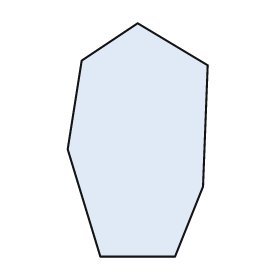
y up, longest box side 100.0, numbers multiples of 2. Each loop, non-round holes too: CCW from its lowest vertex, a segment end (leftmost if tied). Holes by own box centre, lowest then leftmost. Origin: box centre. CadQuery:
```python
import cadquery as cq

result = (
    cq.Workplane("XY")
    .moveTo(-16.0, -50.0)
    .lineTo(16.0, -50.0)
    .lineTo(28.0, -20.0)
    .lineTo(30.0, 32.0)
    .lineTo(0.0, 50.0)
    .lineTo(-24.0, 34.0)
    .lineTo(-30.0, -4.0)
    .close()
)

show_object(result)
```